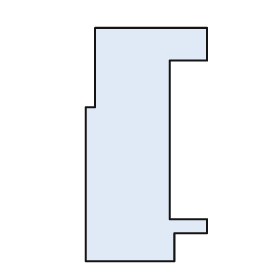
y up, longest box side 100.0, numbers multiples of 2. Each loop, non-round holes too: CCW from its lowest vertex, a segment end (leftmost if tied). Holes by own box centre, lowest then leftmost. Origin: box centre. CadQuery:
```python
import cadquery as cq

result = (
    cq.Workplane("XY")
    .moveTo(-26.0, -50.0)
    .lineTo(12.0, -50.0)
    .lineTo(12.0, -38.0)
    .lineTo(26.0, -38.0)
    .lineTo(26.0, -32.0)
    .lineTo(10.0, -32.0)
    .lineTo(10.0, 36.0)
    .lineTo(26.0, 36.0)
    .lineTo(26.0, 50.0)
    .lineTo(-22.0, 50.0)
    .lineTo(-22.0, 16.0)
    .lineTo(-26.0, 16.0)
    .close()
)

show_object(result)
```